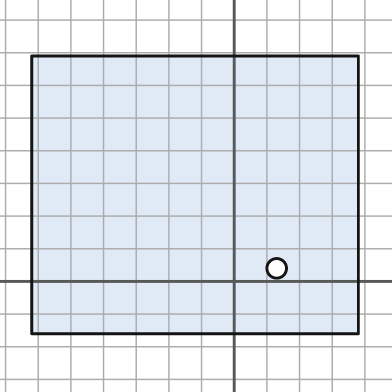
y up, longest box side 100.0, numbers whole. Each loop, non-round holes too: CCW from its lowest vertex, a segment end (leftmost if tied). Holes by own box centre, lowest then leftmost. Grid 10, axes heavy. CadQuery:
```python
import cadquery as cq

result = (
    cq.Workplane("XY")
    .moveTo(-62.0, -16.0)
    .lineTo(38.0, -16.0)
    .lineTo(38.0, 69.0)
    .lineTo(-62.0, 69.0)
    .close()
    .moveTo(13.0, 4.0)
    .circle(3.0)
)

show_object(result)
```